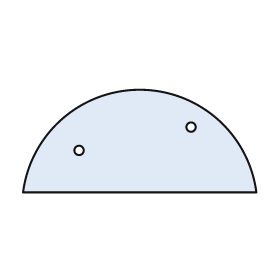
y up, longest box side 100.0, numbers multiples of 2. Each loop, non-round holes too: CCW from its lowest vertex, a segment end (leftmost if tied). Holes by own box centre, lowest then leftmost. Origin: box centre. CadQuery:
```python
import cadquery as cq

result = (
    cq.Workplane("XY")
    .moveTo(-50.0, -22.0)
    .lineTo(50.0, -22.0)
    .threePointArc((0.0, 22.0), (-50.0, -22.0))
    .close()
    .moveTo(-26.0, -4.0)
    .circle(2.0)
    .moveTo(22.0, 6.0)
    .circle(2.0)
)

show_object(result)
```